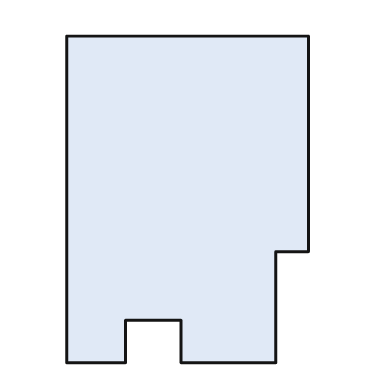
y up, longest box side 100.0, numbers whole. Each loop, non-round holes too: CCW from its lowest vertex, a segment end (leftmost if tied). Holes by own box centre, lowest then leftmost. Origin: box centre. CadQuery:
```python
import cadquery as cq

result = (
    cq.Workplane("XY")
    .moveTo(-37.0, -50.0)
    .lineTo(-19.0, -50.0)
    .lineTo(-19.0, -37.0)
    .lineTo(-2.0, -37.0)
    .lineTo(-2.0, -50.0)
    .lineTo(27.0, -50.0)
    .lineTo(27.0, -16.0)
    .lineTo(37.0, -16.0)
    .lineTo(37.0, 50.0)
    .lineTo(-37.0, 50.0)
    .close()
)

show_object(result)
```